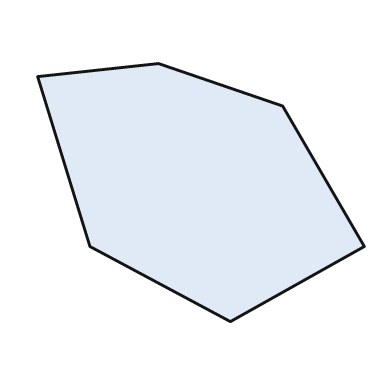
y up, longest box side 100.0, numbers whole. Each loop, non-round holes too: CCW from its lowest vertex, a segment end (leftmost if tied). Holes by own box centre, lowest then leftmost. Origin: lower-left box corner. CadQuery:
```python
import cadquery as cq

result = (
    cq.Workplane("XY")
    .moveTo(59.0, 0.0)
    .lineTo(100.0, 23.0)
    .lineTo(75.0, 66.0)
    .lineTo(37.0, 79.0)
    .lineTo(0.0, 75.0)
    .lineTo(16.0, 23.0)
    .close()
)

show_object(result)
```